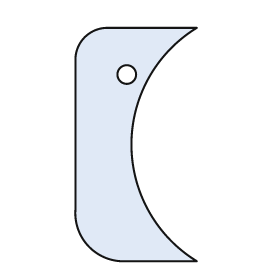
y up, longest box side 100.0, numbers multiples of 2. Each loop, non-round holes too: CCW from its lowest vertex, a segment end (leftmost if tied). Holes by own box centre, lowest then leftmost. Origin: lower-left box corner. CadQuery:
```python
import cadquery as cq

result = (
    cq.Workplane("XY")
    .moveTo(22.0, 0.0)
    .lineTo(52.0, 0.0)
    .threePointArc((24.0, 50.0), (52.0, 100.0))
    .lineTo(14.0, 100.0)
    .threePointArc((4.0, 96.0), (0.0, 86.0))
    .lineTo(0.0, 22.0)
    .threePointArc((6.0, 6.0), (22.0, 0.0))
    .close()
    .moveTo(22.0, 80.0)
    .circle(4.0)
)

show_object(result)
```